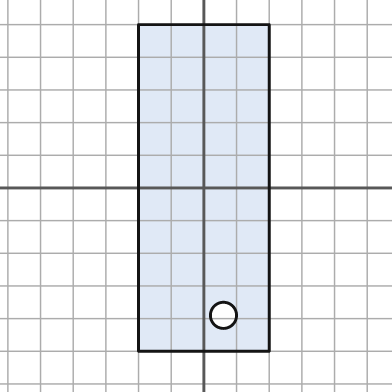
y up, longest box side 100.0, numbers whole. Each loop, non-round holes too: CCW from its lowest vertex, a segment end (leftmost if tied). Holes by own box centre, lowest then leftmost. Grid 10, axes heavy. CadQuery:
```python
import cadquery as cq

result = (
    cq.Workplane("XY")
    .moveTo(-20.0, -50.0)
    .lineTo(20.0, -50.0)
    .lineTo(20.0, 50.0)
    .lineTo(-20.0, 50.0)
    .close()
    .moveTo(6.0, -39.0)
    .circle(4.0)
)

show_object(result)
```